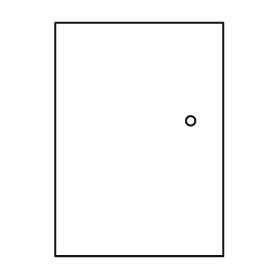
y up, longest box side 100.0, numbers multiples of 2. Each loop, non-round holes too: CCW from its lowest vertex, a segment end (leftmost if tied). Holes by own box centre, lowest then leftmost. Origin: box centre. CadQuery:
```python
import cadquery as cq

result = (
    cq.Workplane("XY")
    .moveTo(-36.0, -50.0)
    .lineTo(36.0, -50.0)
    .lineTo(36.0, 50.0)
    .lineTo(-36.0, 50.0)
    .close()
    .moveTo(22.0, 8.0)
    .circle(2.0)
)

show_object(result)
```